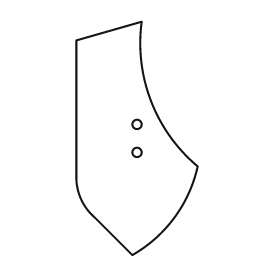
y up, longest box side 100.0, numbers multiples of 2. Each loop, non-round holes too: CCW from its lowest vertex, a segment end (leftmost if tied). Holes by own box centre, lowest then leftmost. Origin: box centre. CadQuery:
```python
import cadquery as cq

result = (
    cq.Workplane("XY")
    .moveTo(-2.0, -50.0)
    .threePointArc((16.0, -34.0), (26.0, -12.0))
    .threePointArc((6.0, 16.0), (2.0, 50.0))
    .lineTo(-26.0, 42.0)
    .lineTo(-26.0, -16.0)
    .threePointArc((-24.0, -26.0), (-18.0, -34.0))
    .close()
    .moveTo(0.0, -6.0)
    .circle(2.0)
    .moveTo(0.0, 6.0)
    .circle(2.0)
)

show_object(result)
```